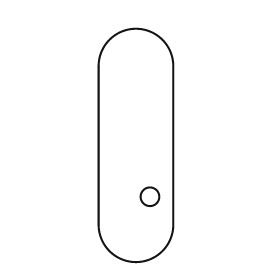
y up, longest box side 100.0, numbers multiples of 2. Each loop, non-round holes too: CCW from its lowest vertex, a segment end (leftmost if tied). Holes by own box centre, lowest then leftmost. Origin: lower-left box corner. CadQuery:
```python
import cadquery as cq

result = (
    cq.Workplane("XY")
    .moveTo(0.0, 16.0)
    .threePointArc((16.0, 0.0), (32.0, 16.0))
    .lineTo(32.0, 84.0)
    .threePointArc((16.0, 100.0), (0.0, 84.0))
    .close()
    .moveTo(22.0, 28.0)
    .circle(4.0)
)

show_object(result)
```